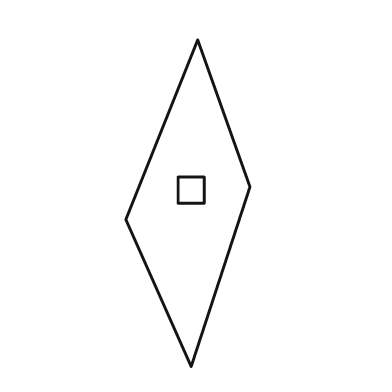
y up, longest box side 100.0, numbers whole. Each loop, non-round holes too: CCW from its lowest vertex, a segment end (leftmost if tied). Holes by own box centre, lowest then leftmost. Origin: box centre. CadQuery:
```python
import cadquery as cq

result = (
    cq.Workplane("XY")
    .moveTo(1.0, -50.0)
    .lineTo(19.0, 5.0)
    .lineTo(3.0, 50.0)
    .lineTo(-19.0, -5.0)
    .close()
    .moveTo(-3.0, 0.0)
    .lineTo(5.0, 0.0)
    .lineTo(5.0, 8.0)
    .lineTo(-3.0, 8.0)
    .close()
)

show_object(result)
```